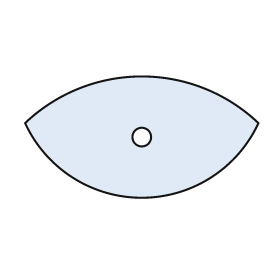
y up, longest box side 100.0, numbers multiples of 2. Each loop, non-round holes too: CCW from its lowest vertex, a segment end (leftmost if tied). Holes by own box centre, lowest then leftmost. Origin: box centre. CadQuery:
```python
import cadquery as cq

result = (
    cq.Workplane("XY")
    .moveTo(-50.0, 6.0)
    .threePointArc((0.0, -26.0), (50.0, 6.0))
    .threePointArc((0.0, 26.0), (-50.0, 6.0))
    .close()
    .moveTo(0.0, 0.0)
    .circle(4.0)
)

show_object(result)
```